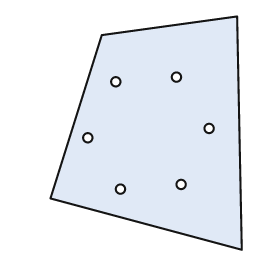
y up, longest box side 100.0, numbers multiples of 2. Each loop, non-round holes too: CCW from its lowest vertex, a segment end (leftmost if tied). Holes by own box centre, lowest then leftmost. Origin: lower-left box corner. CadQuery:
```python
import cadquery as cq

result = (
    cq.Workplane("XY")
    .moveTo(82.0, 0.0)
    .lineTo(80.0, 100.0)
    .lineTo(22.0, 92.0)
    .lineTo(0.0, 22.0)
    .close()
    .moveTo(30.0, 26.0)
    .circle(2.0)
    .moveTo(56.0, 28.0)
    .circle(2.0)
    .moveTo(16.0, 48.0)
    .circle(2.0)
    .moveTo(68.0, 52.0)
    .circle(2.0)
    .moveTo(28.0, 72.0)
    .circle(2.0)
    .moveTo(54.0, 74.0)
    .circle(2.0)
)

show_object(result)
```